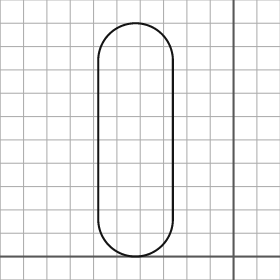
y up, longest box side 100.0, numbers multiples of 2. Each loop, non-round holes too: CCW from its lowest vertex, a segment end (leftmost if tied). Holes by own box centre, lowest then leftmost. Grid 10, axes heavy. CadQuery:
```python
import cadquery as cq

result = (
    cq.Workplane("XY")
    .moveTo(-58.0, 16.0)
    .threePointArc((-42.0, 0.0), (-26.0, 16.0))
    .lineTo(-26.0, 84.0)
    .threePointArc((-42.0, 100.0), (-58.0, 84.0))
    .close()
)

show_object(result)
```